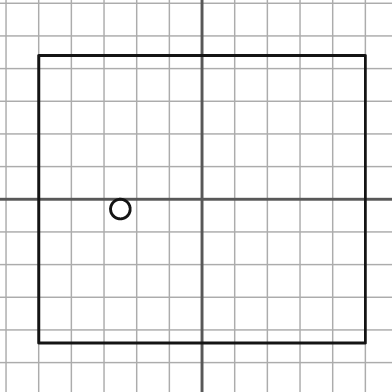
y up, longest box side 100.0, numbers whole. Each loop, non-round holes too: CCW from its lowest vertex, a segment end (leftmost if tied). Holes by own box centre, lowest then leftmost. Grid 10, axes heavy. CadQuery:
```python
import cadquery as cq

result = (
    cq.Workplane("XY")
    .moveTo(-50.0, -44.0)
    .lineTo(50.0, -44.0)
    .lineTo(50.0, 44.0)
    .lineTo(-50.0, 44.0)
    .close()
    .moveTo(-25.0, -3.0)
    .circle(3.0)
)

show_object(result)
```